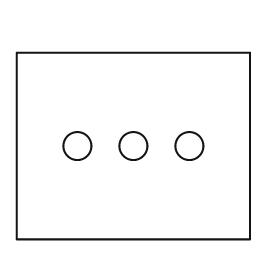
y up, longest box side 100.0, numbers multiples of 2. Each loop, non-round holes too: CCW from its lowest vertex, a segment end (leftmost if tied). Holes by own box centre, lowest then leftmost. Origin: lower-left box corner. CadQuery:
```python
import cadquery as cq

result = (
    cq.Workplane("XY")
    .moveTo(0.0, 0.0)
    .lineTo(100.0, 0.0)
    .lineTo(100.0, 80.0)
    .lineTo(0.0, 80.0)
    .close()
    .moveTo(26.0, 40.0)
    .circle(6.0)
    .moveTo(50.0, 40.0)
    .circle(6.0)
    .moveTo(74.0, 40.0)
    .circle(6.0)
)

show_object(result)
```